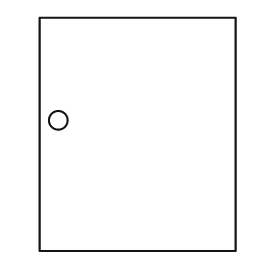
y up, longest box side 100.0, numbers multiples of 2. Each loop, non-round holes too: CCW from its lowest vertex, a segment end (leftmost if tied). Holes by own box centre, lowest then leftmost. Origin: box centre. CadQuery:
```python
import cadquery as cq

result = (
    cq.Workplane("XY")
    .moveTo(-42.0, -50.0)
    .lineTo(42.0, -50.0)
    .lineTo(42.0, 50.0)
    .lineTo(-42.0, 50.0)
    .close()
    .moveTo(-34.0, 6.0)
    .circle(4.0)
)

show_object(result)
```